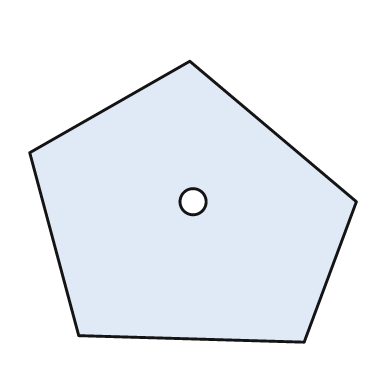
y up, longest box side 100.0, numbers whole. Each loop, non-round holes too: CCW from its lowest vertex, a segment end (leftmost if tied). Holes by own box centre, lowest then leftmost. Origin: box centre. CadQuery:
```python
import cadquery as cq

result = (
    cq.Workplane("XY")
    .moveTo(34.0, -43.0)
    .lineTo(50.0, 0.0)
    .lineTo(-1.0, 43.0)
    .lineTo(-50.0, 15.0)
    .lineTo(-35.0, -41.0)
    .close()
    .moveTo(0.0, 0.0)
    .circle(4.0)
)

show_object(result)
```